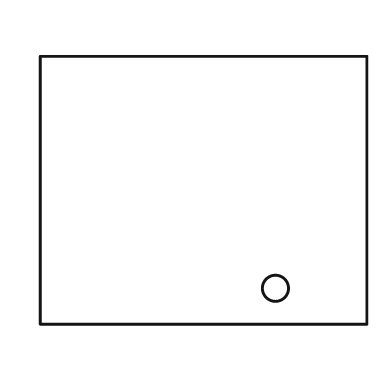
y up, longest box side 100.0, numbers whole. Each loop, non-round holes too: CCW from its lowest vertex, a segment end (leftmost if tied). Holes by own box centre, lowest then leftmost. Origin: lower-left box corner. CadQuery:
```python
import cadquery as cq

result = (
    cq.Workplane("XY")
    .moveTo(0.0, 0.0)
    .lineTo(100.0, 0.0)
    .lineTo(100.0, 82.0)
    .lineTo(0.0, 82.0)
    .close()
    .moveTo(72.0, 11.0)
    .circle(4.0)
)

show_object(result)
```